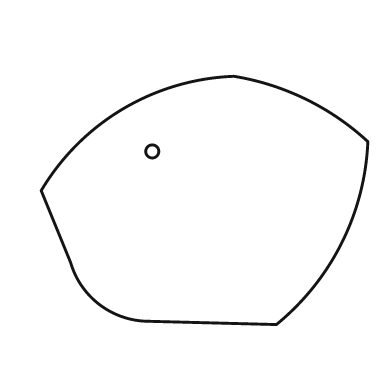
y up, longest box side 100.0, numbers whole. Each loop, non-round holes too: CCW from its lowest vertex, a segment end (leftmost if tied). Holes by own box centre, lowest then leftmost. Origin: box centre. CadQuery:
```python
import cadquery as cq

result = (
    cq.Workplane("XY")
    .moveTo(22.0, -38.0)
    .threePointArc((42.0, -13.0), (50.0, 18.0))
    .threePointArc((31.0, 31.0), (9.0, 38.0))
    .threePointArc((-25.0, 28.0), (-50.0, 3.0))
    .lineTo(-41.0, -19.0)
    .threePointArc((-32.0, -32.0), (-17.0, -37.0))
    .close()
    .moveTo(-16.0, 15.0)
    .circle(2.0)
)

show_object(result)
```